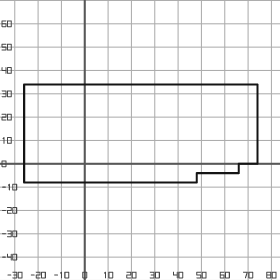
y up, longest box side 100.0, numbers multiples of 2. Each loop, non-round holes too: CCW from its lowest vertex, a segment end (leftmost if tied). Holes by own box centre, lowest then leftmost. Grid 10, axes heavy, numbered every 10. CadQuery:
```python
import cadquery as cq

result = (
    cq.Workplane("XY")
    .moveTo(-26.0, -8.0)
    .lineTo(48.0, -8.0)
    .lineTo(48.0, -4.0)
    .lineTo(66.0, -4.0)
    .lineTo(66.0, 0.0)
    .lineTo(74.0, 0.0)
    .lineTo(74.0, 34.0)
    .lineTo(-26.0, 34.0)
    .close()
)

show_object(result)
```